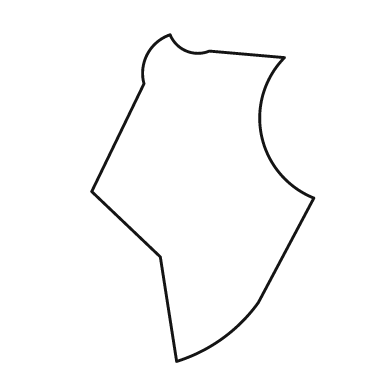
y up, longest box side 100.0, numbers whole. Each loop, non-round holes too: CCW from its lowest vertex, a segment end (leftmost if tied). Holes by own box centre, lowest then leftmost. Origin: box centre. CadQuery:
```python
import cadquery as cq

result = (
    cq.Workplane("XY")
    .moveTo(-8.0, -50.0)
    .threePointArc((6.0, -43.0), (17.0, -32.0))
    .lineTo(34.0, 0.0)
    .threePointArc((18.0, 19.0), (25.0, 43.0))
    .lineTo(2.0, 45.0)
    .threePointArc((-5.0, 45.0), (-10.0, 50.0))
    .threePointArc((-17.0, 44.0), (-18.0, 35.0))
    .lineTo(-34.0, 2.0)
    .lineTo(-13.0, -18.0)
    .close()
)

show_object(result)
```